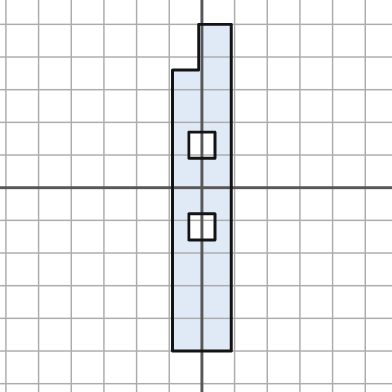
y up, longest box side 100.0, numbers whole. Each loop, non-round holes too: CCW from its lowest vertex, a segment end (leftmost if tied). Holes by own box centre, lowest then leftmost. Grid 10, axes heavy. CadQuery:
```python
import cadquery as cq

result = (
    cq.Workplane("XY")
    .moveTo(-9.0, -50.0)
    .lineTo(9.0, -50.0)
    .lineTo(9.0, 50.0)
    .lineTo(-1.0, 50.0)
    .lineTo(-1.0, 36.0)
    .lineTo(-9.0, 36.0)
    .close()
    .moveTo(-4.0, -16.0)
    .lineTo(4.0, -16.0)
    .lineTo(4.0, -8.0)
    .lineTo(-4.0, -8.0)
    .close()
    .moveTo(-4.0, 9.0)
    .lineTo(4.0, 9.0)
    .lineTo(4.0, 17.0)
    .lineTo(-4.0, 17.0)
    .close()
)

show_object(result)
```